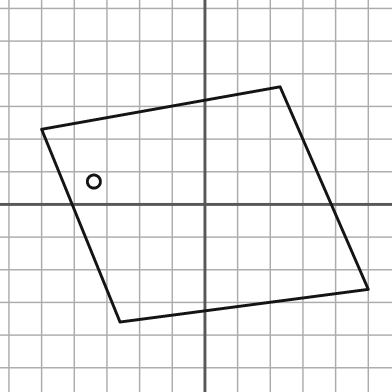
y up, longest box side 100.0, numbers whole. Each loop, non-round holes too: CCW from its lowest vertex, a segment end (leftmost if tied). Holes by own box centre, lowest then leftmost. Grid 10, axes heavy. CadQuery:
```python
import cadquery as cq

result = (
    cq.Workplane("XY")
    .moveTo(-26.0, -36.0)
    .lineTo(50.0, -26.0)
    .lineTo(23.0, 36.0)
    .lineTo(-50.0, 23.0)
    .close()
    .moveTo(-34.0, 7.0)
    .circle(2.0)
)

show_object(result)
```